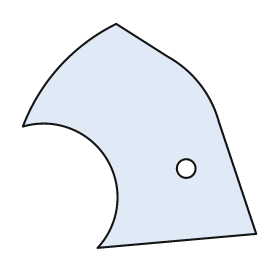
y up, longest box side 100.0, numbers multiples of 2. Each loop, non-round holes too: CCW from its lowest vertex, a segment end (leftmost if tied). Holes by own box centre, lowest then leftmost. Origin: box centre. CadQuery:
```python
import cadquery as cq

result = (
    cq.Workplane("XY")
    .moveTo(-18.0, -48.0)
    .lineTo(50.0, -42.0)
    .lineTo(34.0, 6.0)
    .threePointArc((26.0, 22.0), (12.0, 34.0))
    .lineTo(-10.0, 48.0)
    .threePointArc((-34.0, 30.0), (-50.0, 4.0))
    .threePointArc((-14.0, -10.0), (-18.0, -48.0))
    .close()
    .moveTo(20.0, -14.0)
    .circle(4.0)
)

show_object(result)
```